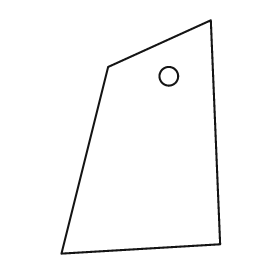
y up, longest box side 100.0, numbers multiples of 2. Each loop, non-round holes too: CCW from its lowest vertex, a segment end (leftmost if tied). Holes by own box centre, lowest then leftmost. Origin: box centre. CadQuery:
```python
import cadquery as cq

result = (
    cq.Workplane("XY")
    .moveTo(-34.0, -50.0)
    .lineTo(34.0, -46.0)
    .lineTo(30.0, 50.0)
    .lineTo(-14.0, 30.0)
    .close()
    .moveTo(12.0, 26.0)
    .circle(4.0)
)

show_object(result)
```